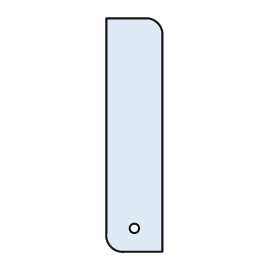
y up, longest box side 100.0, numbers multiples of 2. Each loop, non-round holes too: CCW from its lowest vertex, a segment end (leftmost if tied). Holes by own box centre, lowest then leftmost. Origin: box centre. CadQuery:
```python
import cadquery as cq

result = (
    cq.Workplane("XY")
    .moveTo(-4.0, -50.0)
    .lineTo(12.0, -50.0)
    .lineTo(12.0, 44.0)
    .threePointArc((10.0, 48.0), (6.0, 50.0))
    .lineTo(-12.0, 50.0)
    .lineTo(-12.0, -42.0)
    .threePointArc((-10.0, -48.0), (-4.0, -50.0))
    .close()
    .moveTo(0.0, -40.0)
    .circle(2.0)
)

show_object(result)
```